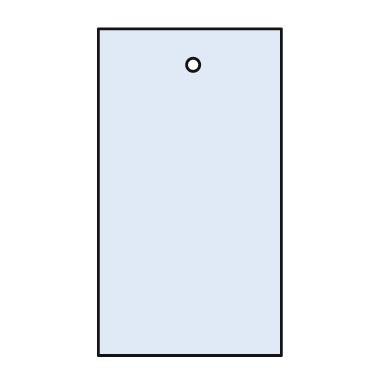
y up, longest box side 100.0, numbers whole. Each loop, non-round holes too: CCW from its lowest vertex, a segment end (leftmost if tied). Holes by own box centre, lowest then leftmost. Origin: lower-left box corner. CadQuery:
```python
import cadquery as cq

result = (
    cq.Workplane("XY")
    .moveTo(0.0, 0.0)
    .lineTo(56.0, 0.0)
    .lineTo(56.0, 100.0)
    .lineTo(0.0, 100.0)
    .close()
    .moveTo(29.0, 89.0)
    .circle(2.0)
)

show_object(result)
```